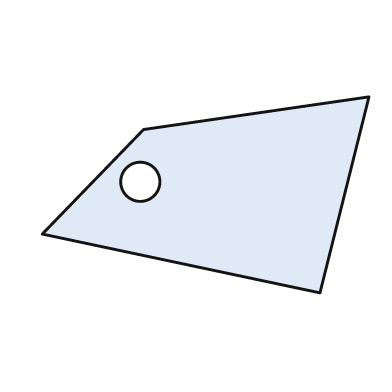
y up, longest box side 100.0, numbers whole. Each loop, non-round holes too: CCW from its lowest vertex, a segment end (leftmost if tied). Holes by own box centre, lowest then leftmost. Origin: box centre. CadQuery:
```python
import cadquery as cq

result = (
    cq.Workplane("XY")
    .moveTo(35.0, -30.0)
    .lineTo(50.0, 30.0)
    .lineTo(-19.0, 20.0)
    .lineTo(-50.0, -12.0)
    .close()
    .moveTo(-20.0, 4.0)
    .circle(6.0)
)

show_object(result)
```